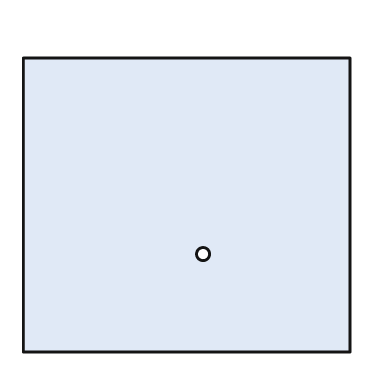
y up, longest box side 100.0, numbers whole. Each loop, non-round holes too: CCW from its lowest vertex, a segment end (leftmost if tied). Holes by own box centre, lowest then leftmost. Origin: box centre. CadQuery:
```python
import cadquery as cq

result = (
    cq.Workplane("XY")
    .moveTo(-50.0, -45.0)
    .lineTo(50.0, -45.0)
    .lineTo(50.0, 45.0)
    .lineTo(-50.0, 45.0)
    .close()
    .moveTo(5.0, -15.0)
    .circle(2.0)
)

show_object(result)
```